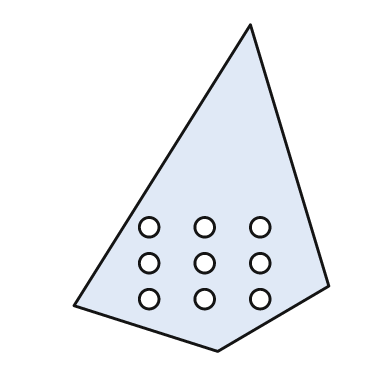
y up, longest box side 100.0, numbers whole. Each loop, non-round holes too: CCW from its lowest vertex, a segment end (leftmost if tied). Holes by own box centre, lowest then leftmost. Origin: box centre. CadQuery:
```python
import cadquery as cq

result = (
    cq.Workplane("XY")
    .moveTo(5.0, -50.0)
    .lineTo(39.0, -30.0)
    .lineTo(15.0, 50.0)
    .lineTo(-39.0, -36.0)
    .close()
    .moveTo(-16.0, -34.0)
    .circle(3.0)
    .moveTo(1.0, -34.0)
    .circle(3.0)
    .moveTo(18.0, -34.0)
    .circle(3.0)
    .moveTo(-16.0, -23.0)
    .circle(3.0)
    .moveTo(1.0, -23.0)
    .circle(3.0)
    .moveTo(18.0, -23.0)
    .circle(3.0)
    .moveTo(-16.0, -12.0)
    .circle(3.0)
    .moveTo(1.0, -12.0)
    .circle(3.0)
    .moveTo(18.0, -12.0)
    .circle(3.0)
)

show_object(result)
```